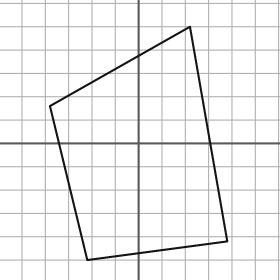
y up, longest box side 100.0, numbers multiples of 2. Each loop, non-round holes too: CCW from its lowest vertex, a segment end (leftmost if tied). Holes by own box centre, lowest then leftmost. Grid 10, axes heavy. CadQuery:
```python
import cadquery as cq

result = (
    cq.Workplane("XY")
    .moveTo(-22.0, -50.0)
    .lineTo(38.0, -42.0)
    .lineTo(22.0, 50.0)
    .lineTo(-38.0, 16.0)
    .close()
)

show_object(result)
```